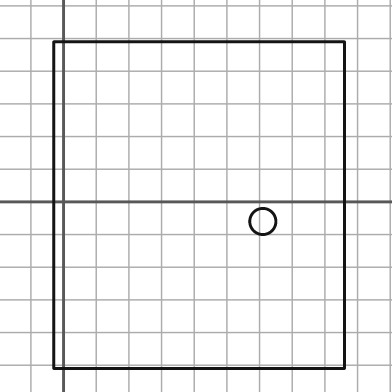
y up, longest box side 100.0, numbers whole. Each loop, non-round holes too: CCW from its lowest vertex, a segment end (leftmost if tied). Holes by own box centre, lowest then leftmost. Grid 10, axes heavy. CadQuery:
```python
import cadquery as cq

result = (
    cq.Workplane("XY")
    .moveTo(-3.0, -51.0)
    .lineTo(86.0, -51.0)
    .lineTo(86.0, 49.0)
    .lineTo(-3.0, 49.0)
    .close()
    .moveTo(61.0, -6.0)
    .circle(4.0)
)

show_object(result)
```